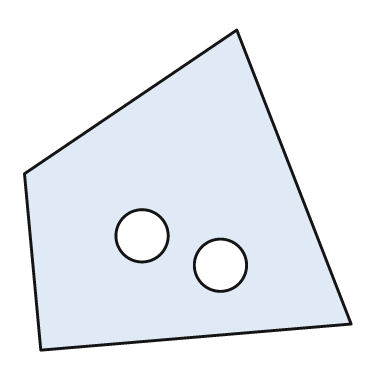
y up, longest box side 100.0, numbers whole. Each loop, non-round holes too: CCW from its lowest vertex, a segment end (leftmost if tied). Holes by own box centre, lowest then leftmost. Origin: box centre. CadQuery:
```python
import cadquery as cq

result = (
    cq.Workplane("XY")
    .moveTo(-45.0, -49.0)
    .lineTo(50.0, -41.0)
    .lineTo(15.0, 49.0)
    .lineTo(-50.0, 5.0)
    .close()
    .moveTo(10.0, -23.0)
    .circle(8.0)
    .moveTo(-14.0, -14.0)
    .circle(8.0)
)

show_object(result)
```